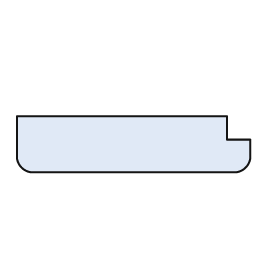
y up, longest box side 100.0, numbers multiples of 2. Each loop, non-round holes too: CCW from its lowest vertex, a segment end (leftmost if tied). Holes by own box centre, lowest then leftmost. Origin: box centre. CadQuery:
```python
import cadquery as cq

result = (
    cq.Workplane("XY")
    .moveTo(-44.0, -12.0)
    .lineTo(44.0, -12.0)
    .threePointArc((48.0, -10.0), (50.0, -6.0))
    .lineTo(50.0, 2.0)
    .lineTo(40.0, 2.0)
    .lineTo(40.0, 12.0)
    .lineTo(-50.0, 12.0)
    .lineTo(-50.0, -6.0)
    .threePointArc((-48.0, -10.0), (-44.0, -12.0))
    .close()
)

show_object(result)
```